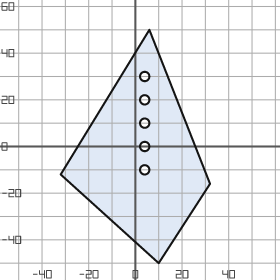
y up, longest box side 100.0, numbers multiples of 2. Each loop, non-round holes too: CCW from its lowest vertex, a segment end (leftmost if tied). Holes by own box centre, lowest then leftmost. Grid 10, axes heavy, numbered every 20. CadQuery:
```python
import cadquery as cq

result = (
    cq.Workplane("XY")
    .moveTo(10.0, -50.0)
    .lineTo(32.0, -16.0)
    .lineTo(6.0, 50.0)
    .lineTo(-32.0, -12.0)
    .close()
    .moveTo(4.0, -10.0)
    .circle(2.0)
    .moveTo(4.0, 0.0)
    .circle(2.0)
    .moveTo(4.0, 10.0)
    .circle(2.0)
    .moveTo(4.0, 20.0)
    .circle(2.0)
    .moveTo(4.0, 30.0)
    .circle(2.0)
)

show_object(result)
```